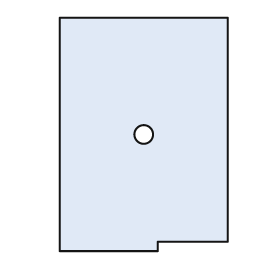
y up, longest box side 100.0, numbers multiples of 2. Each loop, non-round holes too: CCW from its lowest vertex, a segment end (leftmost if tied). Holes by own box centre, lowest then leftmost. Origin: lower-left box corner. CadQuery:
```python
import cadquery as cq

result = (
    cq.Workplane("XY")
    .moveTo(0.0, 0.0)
    .lineTo(42.0, 0.0)
    .lineTo(42.0, 4.0)
    .lineTo(72.0, 4.0)
    .lineTo(72.0, 100.0)
    .lineTo(0.0, 100.0)
    .close()
    .moveTo(36.0, 50.0)
    .circle(4.0)
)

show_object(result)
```